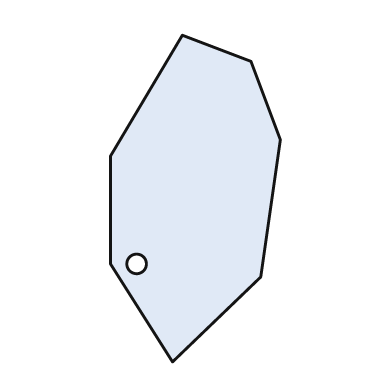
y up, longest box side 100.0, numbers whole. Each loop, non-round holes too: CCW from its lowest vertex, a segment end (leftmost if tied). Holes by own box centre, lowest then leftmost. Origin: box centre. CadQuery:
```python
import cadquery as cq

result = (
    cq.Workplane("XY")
    .moveTo(-7.0, -50.0)
    .lineTo(20.0, -24.0)
    .lineTo(26.0, 18.0)
    .lineTo(17.0, 42.0)
    .lineTo(-4.0, 50.0)
    .lineTo(-26.0, 13.0)
    .lineTo(-26.0, -20.0)
    .close()
    .moveTo(-18.0, -20.0)
    .circle(3.0)
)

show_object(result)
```